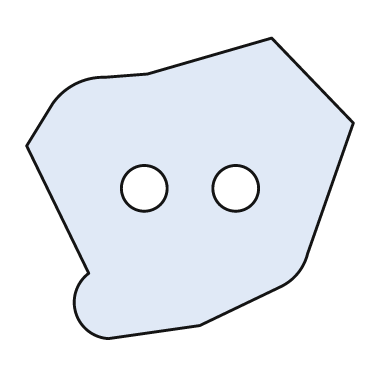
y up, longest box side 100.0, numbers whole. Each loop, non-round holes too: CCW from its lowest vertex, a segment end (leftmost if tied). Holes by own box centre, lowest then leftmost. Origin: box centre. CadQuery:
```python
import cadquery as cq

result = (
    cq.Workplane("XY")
    .moveTo(-25.0, -46.0)
    .lineTo(3.0, -42.0)
    .lineTo(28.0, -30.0)
    .threePointArc((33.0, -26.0), (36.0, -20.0))
    .lineTo(50.0, 20.0)
    .lineTo(25.0, 46.0)
    .lineTo(-13.0, 35.0)
    .lineTo(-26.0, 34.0)
    .threePointArc((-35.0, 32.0), (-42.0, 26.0))
    .lineTo(-50.0, 13.0)
    .lineTo(-31.0, -26.0)
    .threePointArc((-35.0, -38.0), (-25.0, -46.0))
    .close()
    .moveTo(-14.0, 0.0)
    .circle(7.0)
    .moveTo(14.0, 0.0)
    .circle(7.0)
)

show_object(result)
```